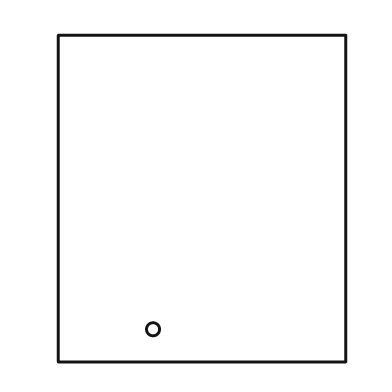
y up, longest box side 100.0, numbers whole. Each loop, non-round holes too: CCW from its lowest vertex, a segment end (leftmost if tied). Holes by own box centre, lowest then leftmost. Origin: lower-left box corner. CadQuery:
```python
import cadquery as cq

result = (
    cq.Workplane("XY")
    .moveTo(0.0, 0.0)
    .lineTo(88.0, 0.0)
    .lineTo(88.0, 100.0)
    .lineTo(0.0, 100.0)
    .close()
    .moveTo(29.0, 10.0)
    .circle(2.0)
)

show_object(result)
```